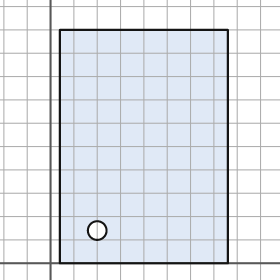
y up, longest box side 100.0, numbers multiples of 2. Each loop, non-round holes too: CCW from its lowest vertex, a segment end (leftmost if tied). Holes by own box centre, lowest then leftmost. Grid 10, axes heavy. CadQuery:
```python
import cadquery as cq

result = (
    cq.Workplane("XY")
    .moveTo(4.0, 0.0)
    .lineTo(76.0, 0.0)
    .lineTo(76.0, 100.0)
    .lineTo(4.0, 100.0)
    .close()
    .moveTo(20.0, 14.0)
    .circle(4.0)
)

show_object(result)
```